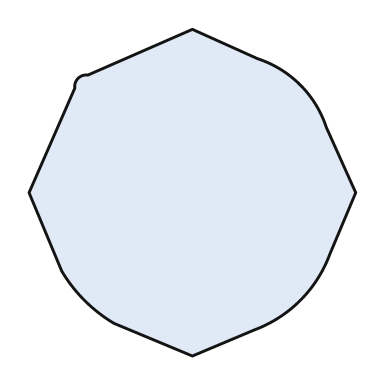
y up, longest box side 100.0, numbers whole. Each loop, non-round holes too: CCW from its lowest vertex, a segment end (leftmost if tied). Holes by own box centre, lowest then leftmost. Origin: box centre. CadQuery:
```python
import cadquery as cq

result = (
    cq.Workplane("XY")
    .moveTo(0.0, -50.0)
    .lineTo(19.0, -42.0)
    .threePointArc((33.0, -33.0), (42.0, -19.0))
    .lineTo(50.0, 0.0)
    .lineTo(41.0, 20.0)
    .threePointArc((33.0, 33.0), (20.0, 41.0))
    .lineTo(0.0, 50.0)
    .lineTo(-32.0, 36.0)
    .threePointArc((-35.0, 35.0), (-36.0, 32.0))
    .lineTo(-50.0, 0.0)
    .lineTo(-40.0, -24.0)
    .threePointArc((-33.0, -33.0), (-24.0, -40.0))
    .close()
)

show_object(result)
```